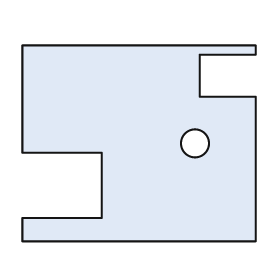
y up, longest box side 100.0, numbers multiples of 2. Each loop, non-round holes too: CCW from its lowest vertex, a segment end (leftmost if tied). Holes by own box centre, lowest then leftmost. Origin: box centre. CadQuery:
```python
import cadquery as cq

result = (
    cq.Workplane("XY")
    .moveTo(-50.0, -42.0)
    .lineTo(50.0, -42.0)
    .lineTo(50.0, 20.0)
    .lineTo(26.0, 20.0)
    .lineTo(26.0, 38.0)
    .lineTo(50.0, 38.0)
    .lineTo(50.0, 42.0)
    .lineTo(-50.0, 42.0)
    .lineTo(-50.0, -4.0)
    .lineTo(-16.0, -4.0)
    .lineTo(-16.0, -32.0)
    .lineTo(-50.0, -32.0)
    .close()
    .moveTo(24.0, 0.0)
    .circle(6.0)
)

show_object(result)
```